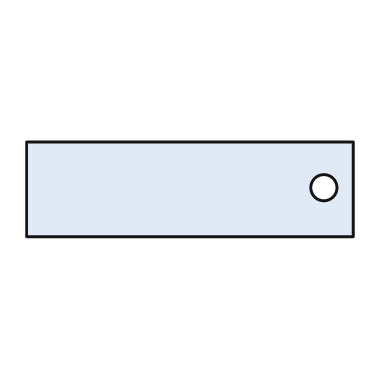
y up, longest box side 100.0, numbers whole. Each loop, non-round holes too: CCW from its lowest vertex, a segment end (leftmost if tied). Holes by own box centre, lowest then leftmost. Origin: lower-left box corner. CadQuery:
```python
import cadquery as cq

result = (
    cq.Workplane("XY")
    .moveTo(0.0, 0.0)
    .lineTo(100.0, 0.0)
    .lineTo(100.0, 29.0)
    .lineTo(0.0, 29.0)
    .close()
    .moveTo(91.0, 15.0)
    .circle(4.0)
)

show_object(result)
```